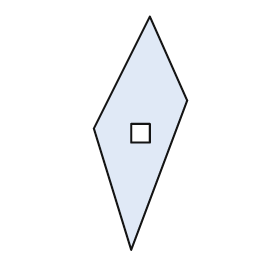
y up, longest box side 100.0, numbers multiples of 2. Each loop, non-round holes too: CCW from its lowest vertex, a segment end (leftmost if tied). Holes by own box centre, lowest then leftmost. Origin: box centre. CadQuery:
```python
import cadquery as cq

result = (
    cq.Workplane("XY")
    .moveTo(-4.0, -50.0)
    .lineTo(20.0, 14.0)
    .lineTo(4.0, 50.0)
    .lineTo(-20.0, 2.0)
    .close()
    .moveTo(-4.0, -4.0)
    .lineTo(4.0, -4.0)
    .lineTo(4.0, 4.0)
    .lineTo(-4.0, 4.0)
    .close()
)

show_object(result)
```